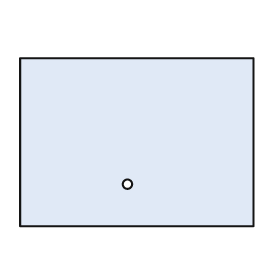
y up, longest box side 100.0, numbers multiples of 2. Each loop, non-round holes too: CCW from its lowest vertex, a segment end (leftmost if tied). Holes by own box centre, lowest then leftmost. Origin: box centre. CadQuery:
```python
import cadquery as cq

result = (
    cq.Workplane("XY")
    .moveTo(-50.0, -36.0)
    .lineTo(50.0, -36.0)
    .lineTo(50.0, 36.0)
    .lineTo(-50.0, 36.0)
    .close()
    .moveTo(-4.0, -18.0)
    .circle(2.0)
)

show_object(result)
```